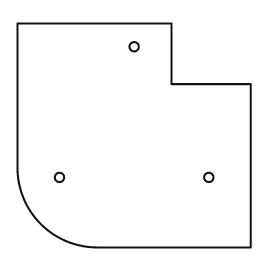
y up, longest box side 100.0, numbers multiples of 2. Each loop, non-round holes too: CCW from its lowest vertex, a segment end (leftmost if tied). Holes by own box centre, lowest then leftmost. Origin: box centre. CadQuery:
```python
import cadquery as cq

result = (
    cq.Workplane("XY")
    .moveTo(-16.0, -48.0)
    .lineTo(50.0, -48.0)
    .lineTo(50.0, 22.0)
    .lineTo(16.0, 22.0)
    .lineTo(16.0, 48.0)
    .lineTo(-50.0, 48.0)
    .lineTo(-50.0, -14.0)
    .threePointArc((-40.0, -38.0), (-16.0, -48.0))
    .close()
    .moveTo(-32.0, -18.0)
    .circle(2.0)
    .moveTo(32.0, -18.0)
    .circle(2.0)
    .moveTo(0.0, 38.0)
    .circle(2.0)
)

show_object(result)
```